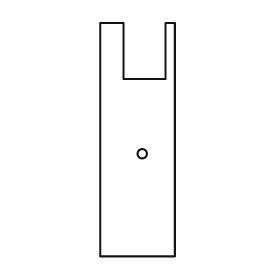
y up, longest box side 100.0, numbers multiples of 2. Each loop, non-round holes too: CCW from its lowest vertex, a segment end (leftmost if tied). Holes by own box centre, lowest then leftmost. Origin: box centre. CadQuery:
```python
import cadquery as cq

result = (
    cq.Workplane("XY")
    .moveTo(-16.0, -50.0)
    .lineTo(16.0, -50.0)
    .lineTo(16.0, 50.0)
    .lineTo(12.0, 50.0)
    .lineTo(12.0, 26.0)
    .lineTo(-6.0, 26.0)
    .lineTo(-6.0, 50.0)
    .lineTo(-16.0, 50.0)
    .close()
    .moveTo(2.0, -6.0)
    .circle(2.0)
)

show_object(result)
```